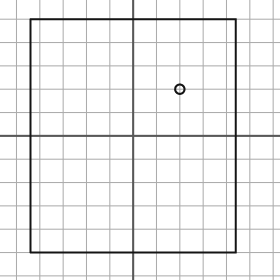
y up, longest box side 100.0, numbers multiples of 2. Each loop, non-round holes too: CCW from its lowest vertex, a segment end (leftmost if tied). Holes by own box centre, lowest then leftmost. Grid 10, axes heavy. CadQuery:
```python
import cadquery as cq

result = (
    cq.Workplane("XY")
    .moveTo(-44.0, -50.0)
    .lineTo(44.0, -50.0)
    .lineTo(44.0, 50.0)
    .lineTo(-44.0, 50.0)
    .close()
    .moveTo(20.0, 20.0)
    .circle(2.0)
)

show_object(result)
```